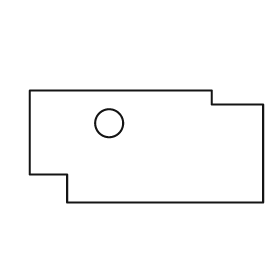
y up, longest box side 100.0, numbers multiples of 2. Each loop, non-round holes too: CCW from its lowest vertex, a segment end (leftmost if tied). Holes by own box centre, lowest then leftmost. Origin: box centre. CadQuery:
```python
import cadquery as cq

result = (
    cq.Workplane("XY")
    .moveTo(-34.0, -24.0)
    .lineTo(50.0, -24.0)
    .lineTo(50.0, 18.0)
    .lineTo(28.0, 18.0)
    .lineTo(28.0, 24.0)
    .lineTo(-50.0, 24.0)
    .lineTo(-50.0, -12.0)
    .lineTo(-34.0, -12.0)
    .close()
    .moveTo(-16.0, 10.0)
    .circle(6.0)
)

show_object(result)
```